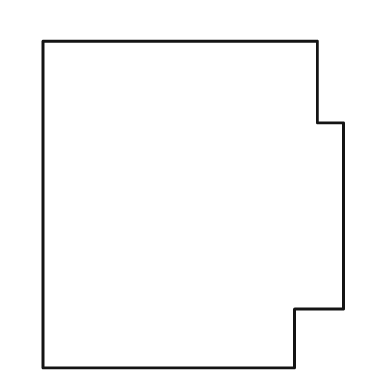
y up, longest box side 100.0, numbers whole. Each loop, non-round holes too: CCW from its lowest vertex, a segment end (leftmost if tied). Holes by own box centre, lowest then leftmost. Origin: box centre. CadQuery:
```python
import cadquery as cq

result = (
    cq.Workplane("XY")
    .moveTo(-46.0, -50.0)
    .lineTo(31.0, -50.0)
    .lineTo(31.0, -32.0)
    .lineTo(46.0, -32.0)
    .lineTo(46.0, 25.0)
    .lineTo(38.0, 25.0)
    .lineTo(38.0, 50.0)
    .lineTo(-46.0, 50.0)
    .close()
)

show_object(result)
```